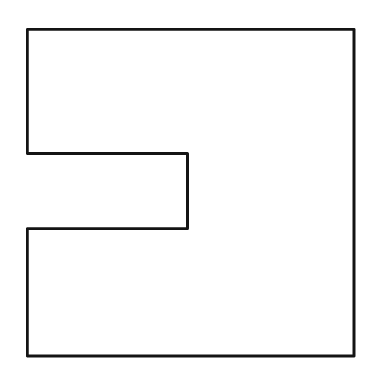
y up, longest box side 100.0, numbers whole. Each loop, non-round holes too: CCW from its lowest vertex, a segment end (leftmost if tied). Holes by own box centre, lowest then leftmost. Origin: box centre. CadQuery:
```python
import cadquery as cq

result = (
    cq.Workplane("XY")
    .moveTo(-50.0, -50.0)
    .lineTo(50.0, -50.0)
    .lineTo(50.0, 50.0)
    .lineTo(-50.0, 50.0)
    .lineTo(-50.0, 12.0)
    .lineTo(-1.0, 12.0)
    .lineTo(-1.0, -11.0)
    .lineTo(-50.0, -11.0)
    .close()
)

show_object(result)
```